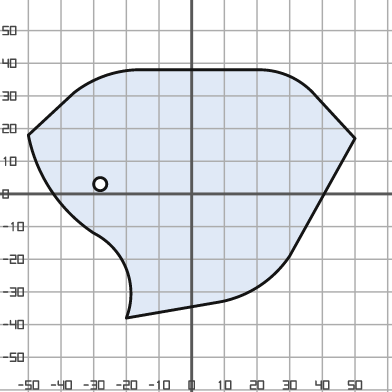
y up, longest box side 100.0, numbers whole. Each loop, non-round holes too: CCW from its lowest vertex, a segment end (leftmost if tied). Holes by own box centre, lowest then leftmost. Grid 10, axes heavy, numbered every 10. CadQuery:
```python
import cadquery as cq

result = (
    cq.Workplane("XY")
    .moveTo(-20.0, -38.0)
    .lineTo(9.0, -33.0)
    .threePointArc((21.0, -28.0), (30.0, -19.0))
    .lineTo(50.0, 17.0)
    .lineTo(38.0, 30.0)
    .threePointArc((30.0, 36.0), (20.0, 38.0))
    .lineTo(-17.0, 38.0)
    .threePointArc((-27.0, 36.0), (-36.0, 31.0))
    .lineTo(-50.0, 18.0)
    .threePointArc((-43.0, 1.0), (-30.0, -12.0))
    .threePointArc((-20.0, -23.0), (-20.0, -38.0))
    .close()
    .moveTo(-28.0, 3.0)
    .circle(2.0)
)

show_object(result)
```